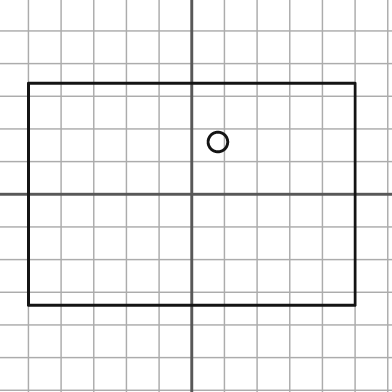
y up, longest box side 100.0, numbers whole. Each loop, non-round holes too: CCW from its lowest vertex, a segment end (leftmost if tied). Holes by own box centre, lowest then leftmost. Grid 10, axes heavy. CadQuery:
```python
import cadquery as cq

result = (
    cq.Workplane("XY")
    .moveTo(-50.0, -34.0)
    .lineTo(50.0, -34.0)
    .lineTo(50.0, 34.0)
    .lineTo(-50.0, 34.0)
    .close()
    .moveTo(8.0, 16.0)
    .circle(3.0)
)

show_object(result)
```